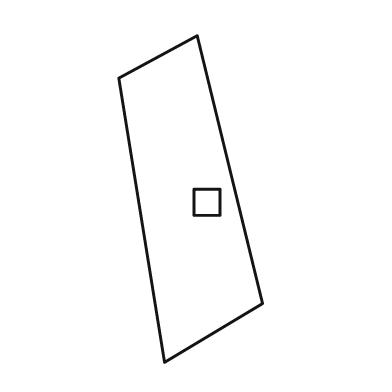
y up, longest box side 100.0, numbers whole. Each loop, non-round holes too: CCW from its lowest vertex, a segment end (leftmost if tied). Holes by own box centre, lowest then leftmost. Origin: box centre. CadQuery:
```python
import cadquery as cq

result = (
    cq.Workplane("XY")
    .moveTo(-8.0, -50.0)
    .lineTo(22.0, -32.0)
    .lineTo(2.0, 50.0)
    .lineTo(-22.0, 37.0)
    .close()
    .moveTo(1.0, -5.0)
    .lineTo(9.0, -5.0)
    .lineTo(9.0, 3.0)
    .lineTo(1.0, 3.0)
    .close()
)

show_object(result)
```